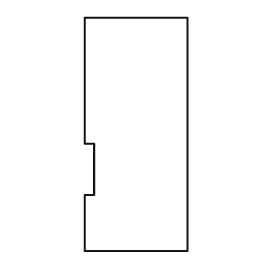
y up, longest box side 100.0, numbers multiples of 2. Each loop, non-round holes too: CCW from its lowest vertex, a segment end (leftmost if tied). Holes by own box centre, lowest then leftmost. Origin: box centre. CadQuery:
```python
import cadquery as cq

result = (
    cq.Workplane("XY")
    .moveTo(-22.0, -50.0)
    .lineTo(22.0, -50.0)
    .lineTo(22.0, 50.0)
    .lineTo(-22.0, 50.0)
    .lineTo(-22.0, -4.0)
    .lineTo(-18.0, -4.0)
    .lineTo(-18.0, -26.0)
    .lineTo(-22.0, -26.0)
    .close()
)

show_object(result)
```